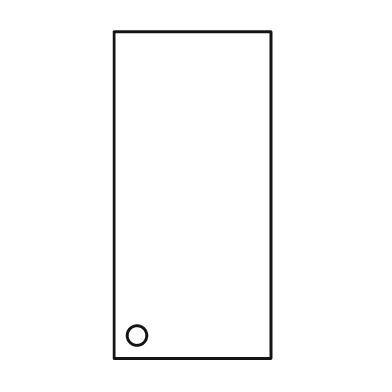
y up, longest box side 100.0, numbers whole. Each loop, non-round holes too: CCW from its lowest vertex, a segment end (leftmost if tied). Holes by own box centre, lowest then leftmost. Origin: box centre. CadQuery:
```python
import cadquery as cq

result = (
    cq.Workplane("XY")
    .moveTo(-24.0, -50.0)
    .lineTo(24.0, -50.0)
    .lineTo(24.0, 50.0)
    .lineTo(-24.0, 50.0)
    .close()
    .moveTo(-17.0, -43.0)
    .circle(3.0)
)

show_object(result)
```